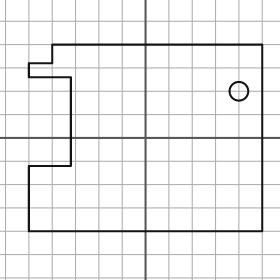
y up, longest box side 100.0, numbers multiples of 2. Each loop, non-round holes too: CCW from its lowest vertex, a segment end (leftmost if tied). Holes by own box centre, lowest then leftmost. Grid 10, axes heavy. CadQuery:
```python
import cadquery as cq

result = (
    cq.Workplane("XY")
    .moveTo(-50.0, -40.0)
    .lineTo(50.0, -40.0)
    .lineTo(50.0, 40.0)
    .lineTo(-40.0, 40.0)
    .lineTo(-40.0, 32.0)
    .lineTo(-50.0, 32.0)
    .lineTo(-50.0, 26.0)
    .lineTo(-32.0, 26.0)
    .lineTo(-32.0, -12.0)
    .lineTo(-50.0, -12.0)
    .close()
    .moveTo(40.0, 20.0)
    .circle(4.0)
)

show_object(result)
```